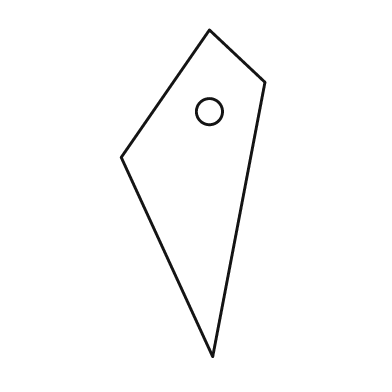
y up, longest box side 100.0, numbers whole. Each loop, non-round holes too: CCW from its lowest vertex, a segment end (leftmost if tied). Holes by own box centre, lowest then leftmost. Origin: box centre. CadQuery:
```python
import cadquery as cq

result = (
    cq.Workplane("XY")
    .moveTo(6.0, -50.0)
    .lineTo(22.0, 34.0)
    .lineTo(5.0, 50.0)
    .lineTo(-22.0, 11.0)
    .close()
    .moveTo(5.0, 25.0)
    .circle(4.0)
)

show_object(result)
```